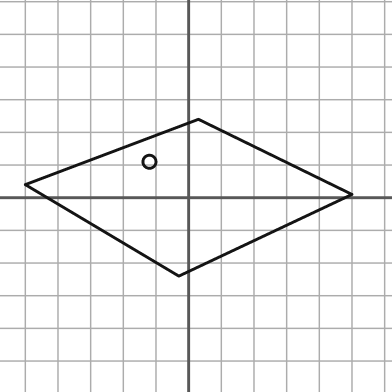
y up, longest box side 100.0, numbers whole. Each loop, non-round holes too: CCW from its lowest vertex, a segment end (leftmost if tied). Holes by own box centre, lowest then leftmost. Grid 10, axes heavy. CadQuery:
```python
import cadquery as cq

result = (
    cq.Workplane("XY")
    .moveTo(-3.0, -24.0)
    .lineTo(50.0, 1.0)
    .lineTo(3.0, 24.0)
    .lineTo(-50.0, 4.0)
    .close()
    .moveTo(-12.0, 11.0)
    .circle(2.0)
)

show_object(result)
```